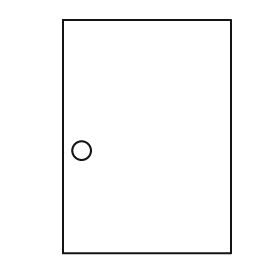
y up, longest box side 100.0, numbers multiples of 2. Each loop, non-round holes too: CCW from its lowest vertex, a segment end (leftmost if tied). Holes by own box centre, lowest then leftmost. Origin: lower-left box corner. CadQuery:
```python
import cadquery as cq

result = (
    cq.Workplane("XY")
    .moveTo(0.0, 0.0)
    .lineTo(72.0, 0.0)
    .lineTo(72.0, 100.0)
    .lineTo(0.0, 100.0)
    .close()
    .moveTo(8.0, 44.0)
    .circle(4.0)
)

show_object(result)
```